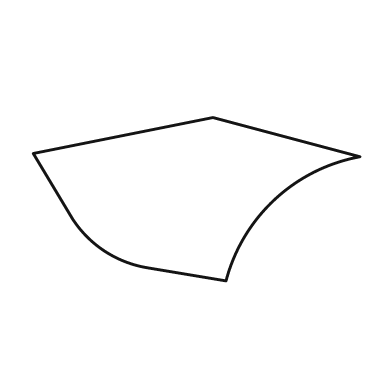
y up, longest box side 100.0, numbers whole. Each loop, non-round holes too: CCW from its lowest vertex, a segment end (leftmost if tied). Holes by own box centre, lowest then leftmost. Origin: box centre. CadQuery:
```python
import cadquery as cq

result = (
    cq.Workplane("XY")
    .moveTo(9.0, -25.0)
    .threePointArc((24.0, 0.0), (50.0, 13.0))
    .lineTo(5.0, 25.0)
    .lineTo(-50.0, 14.0)
    .lineTo(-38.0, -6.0)
    .threePointArc((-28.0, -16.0), (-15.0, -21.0))
    .close()
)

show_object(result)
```